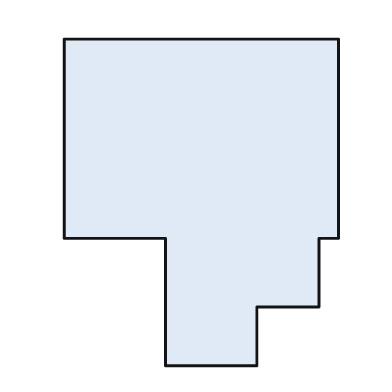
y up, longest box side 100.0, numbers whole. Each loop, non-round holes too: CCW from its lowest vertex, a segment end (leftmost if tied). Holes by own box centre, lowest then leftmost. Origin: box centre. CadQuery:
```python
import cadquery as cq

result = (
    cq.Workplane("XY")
    .moveTo(-11.0, -50.0)
    .lineTo(17.0, -50.0)
    .lineTo(17.0, -32.0)
    .lineTo(36.0, -32.0)
    .lineTo(36.0, -11.0)
    .lineTo(42.0, -11.0)
    .lineTo(42.0, 50.0)
    .lineTo(-42.0, 50.0)
    .lineTo(-42.0, -11.0)
    .lineTo(-11.0, -11.0)
    .close()
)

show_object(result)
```